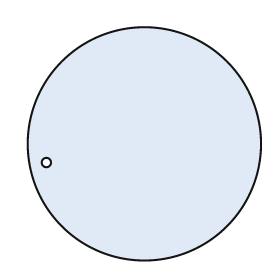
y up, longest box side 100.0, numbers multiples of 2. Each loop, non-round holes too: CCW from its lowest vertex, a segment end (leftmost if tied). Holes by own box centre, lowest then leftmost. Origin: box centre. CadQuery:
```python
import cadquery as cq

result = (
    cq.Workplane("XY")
    .moveTo(0.0, 0.0)
    .circle(50.0)
    .moveTo(-42.0, -8.0)
    .circle(2.0)
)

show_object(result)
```